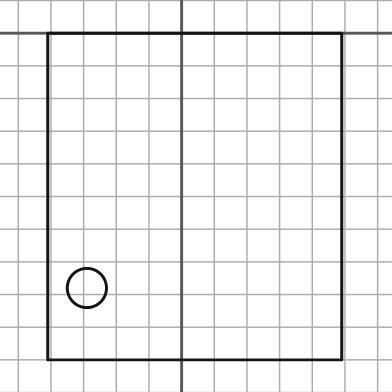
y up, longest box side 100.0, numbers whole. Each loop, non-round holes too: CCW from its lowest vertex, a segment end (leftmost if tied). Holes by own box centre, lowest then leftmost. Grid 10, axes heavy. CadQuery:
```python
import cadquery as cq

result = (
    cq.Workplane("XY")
    .moveTo(-41.0, -100.0)
    .lineTo(49.0, -100.0)
    .lineTo(49.0, 0.0)
    .lineTo(-41.0, 0.0)
    .close()
    .moveTo(-29.0, -78.0)
    .circle(6.0)
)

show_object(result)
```